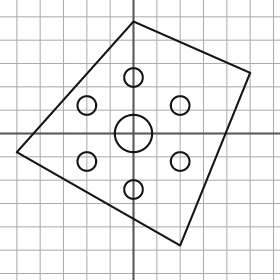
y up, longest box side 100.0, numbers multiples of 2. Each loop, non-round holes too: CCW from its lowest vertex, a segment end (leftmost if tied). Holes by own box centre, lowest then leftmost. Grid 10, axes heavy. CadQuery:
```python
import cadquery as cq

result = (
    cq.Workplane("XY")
    .moveTo(20.0, -48.0)
    .lineTo(50.0, 26.0)
    .lineTo(0.0, 48.0)
    .lineTo(-50.0, -8.0)
    .close()
    .moveTo(0.0, -24.0)
    .circle(4.0)
    .moveTo(-20.0, -12.0)
    .circle(4.0)
    .moveTo(20.0, -12.0)
    .circle(4.0)
    .moveTo(0.0, 0.0)
    .circle(8.0)
    .moveTo(-20.0, 12.0)
    .circle(4.0)
    .moveTo(20.0, 12.0)
    .circle(4.0)
    .moveTo(0.0, 24.0)
    .circle(4.0)
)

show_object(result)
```